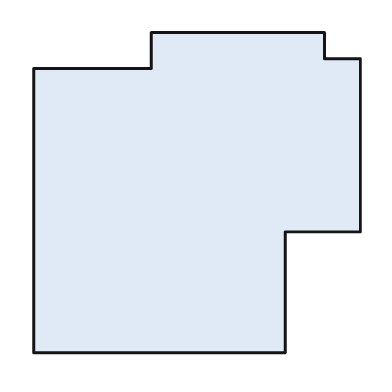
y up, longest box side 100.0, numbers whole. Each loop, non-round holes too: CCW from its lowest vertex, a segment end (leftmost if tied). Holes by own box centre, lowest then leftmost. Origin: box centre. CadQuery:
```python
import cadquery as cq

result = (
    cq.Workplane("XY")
    .moveTo(-50.0, -49.0)
    .lineTo(27.0, -49.0)
    .lineTo(27.0, -12.0)
    .lineTo(50.0, -12.0)
    .lineTo(50.0, 41.0)
    .lineTo(39.0, 41.0)
    .lineTo(39.0, 49.0)
    .lineTo(-14.0, 49.0)
    .lineTo(-14.0, 38.0)
    .lineTo(-50.0, 38.0)
    .close()
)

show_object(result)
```